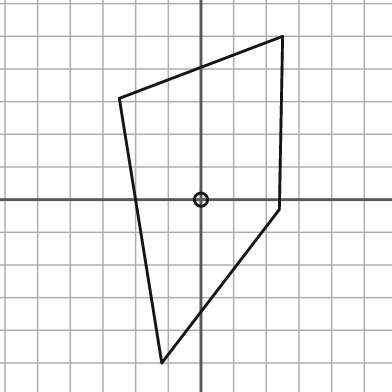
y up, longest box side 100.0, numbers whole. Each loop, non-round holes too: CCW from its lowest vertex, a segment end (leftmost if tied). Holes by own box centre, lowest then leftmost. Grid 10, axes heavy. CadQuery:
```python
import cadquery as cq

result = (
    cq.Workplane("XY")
    .moveTo(-12.0, -50.0)
    .lineTo(24.0, -3.0)
    .lineTo(25.0, 50.0)
    .lineTo(-25.0, 31.0)
    .close()
    .moveTo(0.0, 0.0)
    .circle(2.0)
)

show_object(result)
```